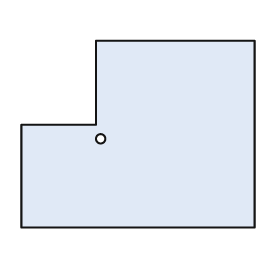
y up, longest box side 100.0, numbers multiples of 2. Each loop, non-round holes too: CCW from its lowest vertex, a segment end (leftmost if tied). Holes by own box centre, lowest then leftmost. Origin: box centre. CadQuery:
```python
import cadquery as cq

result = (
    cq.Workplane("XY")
    .moveTo(-50.0, -40.0)
    .lineTo(50.0, -40.0)
    .lineTo(50.0, 40.0)
    .lineTo(-18.0, 40.0)
    .lineTo(-18.0, 4.0)
    .lineTo(-50.0, 4.0)
    .close()
    .moveTo(-16.0, -2.0)
    .circle(2.0)
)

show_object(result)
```